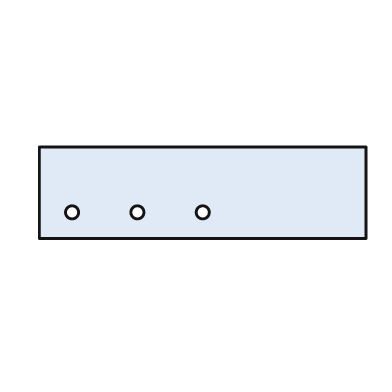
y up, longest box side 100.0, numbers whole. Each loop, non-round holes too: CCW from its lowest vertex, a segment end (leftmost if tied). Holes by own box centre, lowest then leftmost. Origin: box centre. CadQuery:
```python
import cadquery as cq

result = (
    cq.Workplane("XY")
    .moveTo(-50.0, -14.0)
    .lineTo(50.0, -14.0)
    .lineTo(50.0, 14.0)
    .lineTo(-50.0, 14.0)
    .close()
    .moveTo(-40.0, -6.0)
    .circle(2.0)
    .moveTo(-20.0, -6.0)
    .circle(2.0)
    .moveTo(0.0, -6.0)
    .circle(2.0)
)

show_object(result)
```